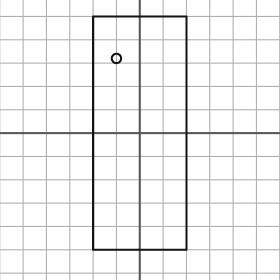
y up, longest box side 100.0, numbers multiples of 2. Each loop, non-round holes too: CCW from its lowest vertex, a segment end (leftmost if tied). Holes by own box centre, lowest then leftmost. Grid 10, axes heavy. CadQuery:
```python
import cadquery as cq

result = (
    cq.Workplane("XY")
    .moveTo(-20.0, -50.0)
    .lineTo(20.0, -50.0)
    .lineTo(20.0, 50.0)
    .lineTo(-20.0, 50.0)
    .close()
    .moveTo(-10.0, 32.0)
    .circle(2.0)
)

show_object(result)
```